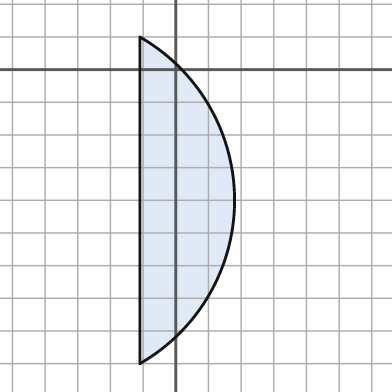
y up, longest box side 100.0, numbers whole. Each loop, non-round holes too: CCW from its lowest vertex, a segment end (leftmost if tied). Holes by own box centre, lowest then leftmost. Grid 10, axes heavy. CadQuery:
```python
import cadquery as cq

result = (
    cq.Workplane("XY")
    .moveTo(-11.0, -90.0)
    .threePointArc((18.0, -40.0), (-11.0, 10.0))
    .close()
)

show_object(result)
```